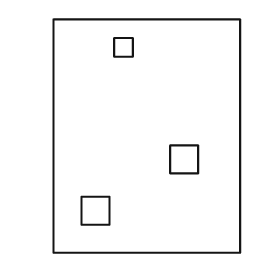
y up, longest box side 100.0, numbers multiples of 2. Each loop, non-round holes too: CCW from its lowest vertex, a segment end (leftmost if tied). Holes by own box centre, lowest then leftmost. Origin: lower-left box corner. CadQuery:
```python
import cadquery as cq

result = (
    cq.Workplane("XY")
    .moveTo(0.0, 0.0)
    .lineTo(80.0, 0.0)
    .lineTo(80.0, 100.0)
    .lineTo(0.0, 100.0)
    .close()
    .moveTo(12.0, 12.0)
    .lineTo(24.0, 12.0)
    .lineTo(24.0, 24.0)
    .lineTo(12.0, 24.0)
    .close()
    .moveTo(50.0, 34.0)
    .lineTo(62.0, 34.0)
    .lineTo(62.0, 46.0)
    .lineTo(50.0, 46.0)
    .close()
    .moveTo(26.0, 84.0)
    .lineTo(34.0, 84.0)
    .lineTo(34.0, 92.0)
    .lineTo(26.0, 92.0)
    .close()
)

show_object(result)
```